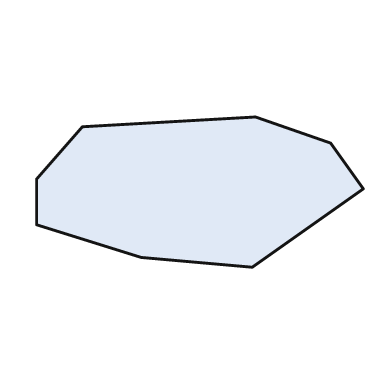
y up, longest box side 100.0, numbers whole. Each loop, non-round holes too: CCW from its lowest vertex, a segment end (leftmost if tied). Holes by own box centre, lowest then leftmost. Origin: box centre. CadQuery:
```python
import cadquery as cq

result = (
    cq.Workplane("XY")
    .moveTo(16.0, -23.0)
    .lineTo(50.0, 1.0)
    .lineTo(40.0, 15.0)
    .lineTo(17.0, 23.0)
    .lineTo(-36.0, 20.0)
    .lineTo(-50.0, 4.0)
    .lineTo(-50.0, -10.0)
    .lineTo(-18.0, -20.0)
    .close()
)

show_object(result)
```